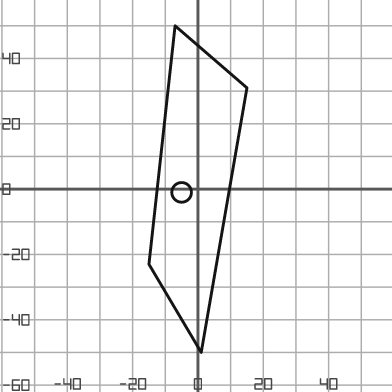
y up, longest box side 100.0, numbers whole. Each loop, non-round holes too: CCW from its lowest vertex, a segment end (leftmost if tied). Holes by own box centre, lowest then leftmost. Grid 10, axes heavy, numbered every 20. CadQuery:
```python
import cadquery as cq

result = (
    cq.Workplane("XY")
    .moveTo(1.0, -50.0)
    .lineTo(15.0, 31.0)
    .lineTo(-7.0, 50.0)
    .lineTo(-15.0, -23.0)
    .close()
    .moveTo(-5.0, -1.0)
    .circle(3.0)
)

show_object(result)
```